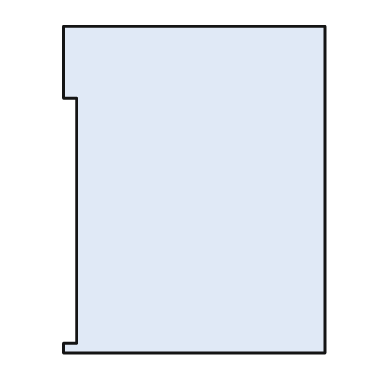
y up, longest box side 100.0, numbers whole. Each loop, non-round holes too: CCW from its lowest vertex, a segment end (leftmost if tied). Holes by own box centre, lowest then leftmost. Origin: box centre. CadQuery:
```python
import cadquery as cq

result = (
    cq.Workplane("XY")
    .moveTo(-40.0, -50.0)
    .lineTo(40.0, -50.0)
    .lineTo(40.0, 50.0)
    .lineTo(-40.0, 50.0)
    .lineTo(-40.0, 28.0)
    .lineTo(-36.0, 28.0)
    .lineTo(-36.0, -47.0)
    .lineTo(-40.0, -47.0)
    .close()
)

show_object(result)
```